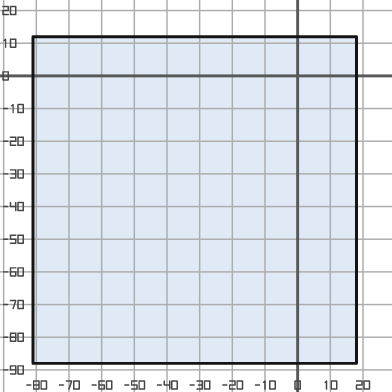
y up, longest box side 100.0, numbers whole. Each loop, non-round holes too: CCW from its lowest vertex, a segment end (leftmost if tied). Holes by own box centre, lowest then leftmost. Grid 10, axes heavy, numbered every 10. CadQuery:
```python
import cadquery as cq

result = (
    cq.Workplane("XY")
    .moveTo(-81.0, -88.0)
    .lineTo(18.0, -88.0)
    .lineTo(18.0, 12.0)
    .lineTo(-81.0, 12.0)
    .close()
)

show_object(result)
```